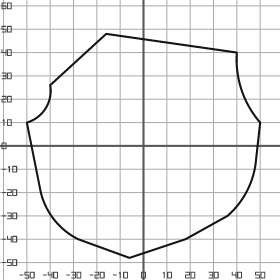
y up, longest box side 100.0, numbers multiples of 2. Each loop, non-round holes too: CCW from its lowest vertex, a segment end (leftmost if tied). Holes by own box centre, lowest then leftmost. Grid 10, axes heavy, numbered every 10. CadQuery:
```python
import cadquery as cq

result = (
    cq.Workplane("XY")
    .moveTo(-6.0, -48.0)
    .lineTo(18.0, -40.0)
    .lineTo(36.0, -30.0)
    .threePointArc((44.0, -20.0), (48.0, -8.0))
    .lineTo(50.0, 10.0)
    .threePointArc((42.0, 24.0), (40.0, 40.0))
    .lineTo(-16.0, 48.0)
    .lineTo(-40.0, 26.0)
    .threePointArc((-42.0, 16.0), (-50.0, 10.0))
    .lineTo(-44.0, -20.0)
    .threePointArc((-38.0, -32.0), (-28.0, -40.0))
    .close()
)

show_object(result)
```